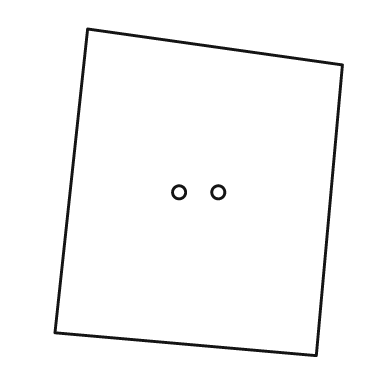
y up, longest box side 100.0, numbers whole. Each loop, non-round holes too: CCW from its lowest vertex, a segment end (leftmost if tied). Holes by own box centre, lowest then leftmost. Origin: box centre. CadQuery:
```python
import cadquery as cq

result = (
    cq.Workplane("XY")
    .moveTo(36.0, -50.0)
    .lineTo(44.0, 39.0)
    .lineTo(-34.0, 50.0)
    .lineTo(-44.0, -43.0)
    .close()
    .moveTo(-6.0, 0.0)
    .circle(2.0)
    .moveTo(6.0, 0.0)
    .circle(2.0)
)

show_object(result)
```